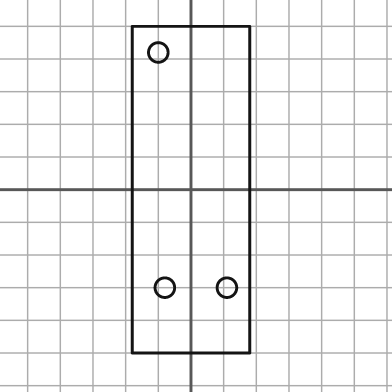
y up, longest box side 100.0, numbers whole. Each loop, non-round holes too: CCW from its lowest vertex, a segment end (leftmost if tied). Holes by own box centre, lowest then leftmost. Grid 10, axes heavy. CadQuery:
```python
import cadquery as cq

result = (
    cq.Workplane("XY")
    .moveTo(-18.0, -50.0)
    .lineTo(18.0, -50.0)
    .lineTo(18.0, 50.0)
    .lineTo(-18.0, 50.0)
    .close()
    .moveTo(-8.0, -30.0)
    .circle(3.0)
    .moveTo(11.0, -30.0)
    .circle(3.0)
    .moveTo(-10.0, 42.0)
    .circle(3.0)
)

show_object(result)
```